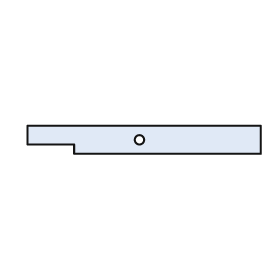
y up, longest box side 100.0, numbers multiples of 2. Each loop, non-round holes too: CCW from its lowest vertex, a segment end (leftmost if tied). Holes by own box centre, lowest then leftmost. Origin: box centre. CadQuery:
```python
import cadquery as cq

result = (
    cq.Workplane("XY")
    .moveTo(-30.0, -6.0)
    .lineTo(50.0, -6.0)
    .lineTo(50.0, 6.0)
    .lineTo(-50.0, 6.0)
    .lineTo(-50.0, -2.0)
    .lineTo(-30.0, -2.0)
    .close()
    .moveTo(-2.0, 0.0)
    .circle(2.0)
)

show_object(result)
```